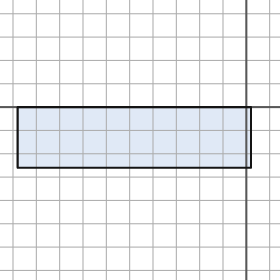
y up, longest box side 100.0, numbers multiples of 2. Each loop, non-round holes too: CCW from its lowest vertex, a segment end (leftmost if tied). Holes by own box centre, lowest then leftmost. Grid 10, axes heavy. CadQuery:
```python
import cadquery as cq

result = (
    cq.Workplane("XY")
    .moveTo(-98.0, -26.0)
    .lineTo(2.0, -26.0)
    .lineTo(2.0, 0.0)
    .lineTo(-98.0, 0.0)
    .close()
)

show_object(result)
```